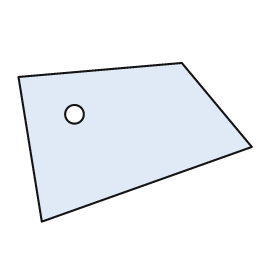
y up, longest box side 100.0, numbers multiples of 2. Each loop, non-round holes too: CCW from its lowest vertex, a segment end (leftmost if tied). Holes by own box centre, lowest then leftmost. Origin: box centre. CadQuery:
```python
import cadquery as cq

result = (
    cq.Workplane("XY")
    .moveTo(-40.0, -34.0)
    .lineTo(50.0, -2.0)
    .lineTo(20.0, 34.0)
    .lineTo(-50.0, 28.0)
    .close()
    .moveTo(-26.0, 12.0)
    .circle(4.0)
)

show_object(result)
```